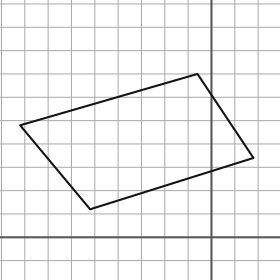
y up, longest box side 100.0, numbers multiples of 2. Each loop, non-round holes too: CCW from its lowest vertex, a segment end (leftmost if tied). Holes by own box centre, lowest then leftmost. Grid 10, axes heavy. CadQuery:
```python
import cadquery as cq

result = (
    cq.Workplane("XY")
    .moveTo(-52.0, 12.0)
    .lineTo(18.0, 34.0)
    .lineTo(-6.0, 70.0)
    .lineTo(-82.0, 48.0)
    .close()
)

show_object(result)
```